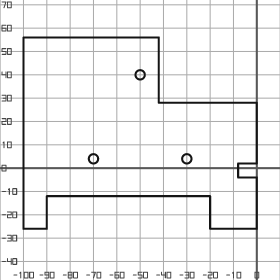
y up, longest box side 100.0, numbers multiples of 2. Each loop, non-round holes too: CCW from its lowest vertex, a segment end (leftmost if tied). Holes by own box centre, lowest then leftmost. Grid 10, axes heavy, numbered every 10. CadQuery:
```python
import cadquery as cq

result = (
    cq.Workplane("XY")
    .moveTo(-100.0, -26.0)
    .lineTo(-90.0, -26.0)
    .lineTo(-90.0, -12.0)
    .lineTo(-20.0, -12.0)
    .lineTo(-20.0, -26.0)
    .lineTo(0.0, -26.0)
    .lineTo(0.0, -4.0)
    .lineTo(-8.0, -4.0)
    .lineTo(-8.0, 2.0)
    .lineTo(0.0, 2.0)
    .lineTo(0.0, 28.0)
    .lineTo(-42.0, 28.0)
    .lineTo(-42.0, 56.0)
    .lineTo(-100.0, 56.0)
    .close()
    .moveTo(-70.0, 4.0)
    .circle(2.0)
    .moveTo(-30.0, 4.0)
    .circle(2.0)
    .moveTo(-50.0, 40.0)
    .circle(2.0)
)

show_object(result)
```